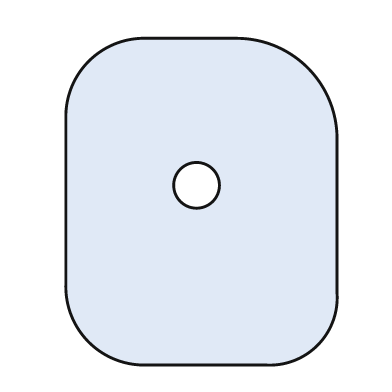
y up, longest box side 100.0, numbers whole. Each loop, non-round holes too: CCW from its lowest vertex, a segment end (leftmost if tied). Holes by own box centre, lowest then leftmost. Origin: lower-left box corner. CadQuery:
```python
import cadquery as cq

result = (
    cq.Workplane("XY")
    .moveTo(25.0, 0.0)
    .lineTo(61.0, 0.0)
    .threePointArc((77.0, 6.0), (83.0, 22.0))
    .lineTo(83.0, 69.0)
    .threePointArc((74.0, 91.0), (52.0, 100.0))
    .lineTo(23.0, 100.0)
    .threePointArc((7.0, 93.0), (0.0, 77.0))
    .lineTo(0.0, 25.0)
    .threePointArc((7.0, 7.0), (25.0, 0.0))
    .close()
    .moveTo(40.0, 55.0)
    .circle(7.0)
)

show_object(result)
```